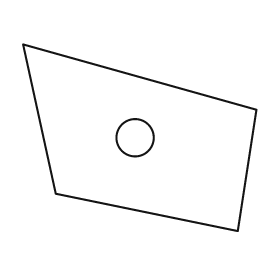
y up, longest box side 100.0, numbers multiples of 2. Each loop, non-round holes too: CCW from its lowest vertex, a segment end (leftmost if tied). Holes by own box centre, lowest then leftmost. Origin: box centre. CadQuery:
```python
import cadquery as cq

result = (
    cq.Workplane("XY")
    .moveTo(42.0, -40.0)
    .lineTo(50.0, 12.0)
    .lineTo(-50.0, 40.0)
    .lineTo(-36.0, -24.0)
    .close()
    .moveTo(-2.0, 0.0)
    .circle(8.0)
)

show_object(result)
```